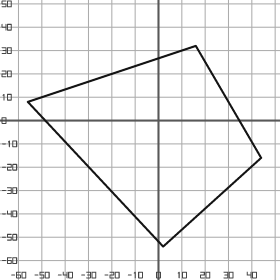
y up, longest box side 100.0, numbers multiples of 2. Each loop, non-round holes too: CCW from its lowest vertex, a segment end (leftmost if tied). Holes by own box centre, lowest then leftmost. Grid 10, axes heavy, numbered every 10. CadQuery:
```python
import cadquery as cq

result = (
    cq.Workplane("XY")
    .moveTo(2.0, -54.0)
    .lineTo(44.0, -16.0)
    .lineTo(16.0, 32.0)
    .lineTo(-56.0, 8.0)
    .close()
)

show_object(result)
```